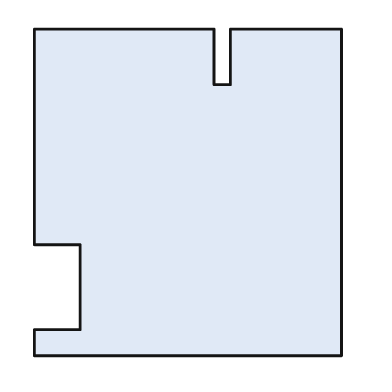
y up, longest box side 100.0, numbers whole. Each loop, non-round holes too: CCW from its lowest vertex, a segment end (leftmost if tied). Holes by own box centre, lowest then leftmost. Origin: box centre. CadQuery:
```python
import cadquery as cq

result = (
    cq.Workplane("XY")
    .moveTo(-47.0, -50.0)
    .lineTo(47.0, -50.0)
    .lineTo(47.0, 50.0)
    .lineTo(13.0, 50.0)
    .lineTo(13.0, 33.0)
    .lineTo(8.0, 33.0)
    .lineTo(8.0, 50.0)
    .lineTo(-47.0, 50.0)
    .lineTo(-47.0, -16.0)
    .lineTo(-33.0, -16.0)
    .lineTo(-33.0, -42.0)
    .lineTo(-47.0, -42.0)
    .close()
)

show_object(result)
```